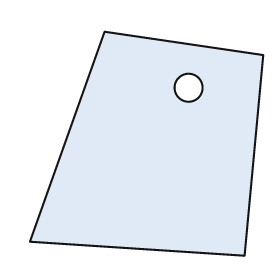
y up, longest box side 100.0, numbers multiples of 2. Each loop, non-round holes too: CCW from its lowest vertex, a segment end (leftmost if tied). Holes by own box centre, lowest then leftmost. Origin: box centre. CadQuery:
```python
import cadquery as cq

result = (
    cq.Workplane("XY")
    .moveTo(42.0, -48.0)
    .lineTo(50.0, 38.0)
    .lineTo(-18.0, 48.0)
    .lineTo(-50.0, -42.0)
    .close()
    .moveTo(18.0, 24.0)
    .circle(6.0)
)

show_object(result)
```